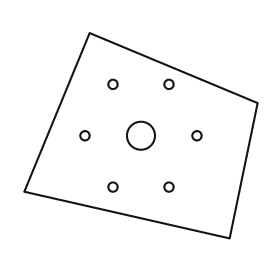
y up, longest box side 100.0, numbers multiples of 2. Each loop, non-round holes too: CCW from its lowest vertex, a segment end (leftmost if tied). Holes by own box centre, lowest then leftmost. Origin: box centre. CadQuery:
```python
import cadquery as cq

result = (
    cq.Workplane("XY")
    .moveTo(38.0, -44.0)
    .lineTo(50.0, 14.0)
    .lineTo(-22.0, 44.0)
    .lineTo(-50.0, -24.0)
    .close()
    .moveTo(-12.0, -22.0)
    .circle(2.0)
    .moveTo(12.0, -22.0)
    .circle(2.0)
    .moveTo(-24.0, 0.0)
    .circle(2.0)
    .moveTo(0.0, 0.0)
    .circle(6.0)
    .moveTo(24.0, 0.0)
    .circle(2.0)
    .moveTo(-12.0, 22.0)
    .circle(2.0)
    .moveTo(12.0, 22.0)
    .circle(2.0)
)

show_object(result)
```